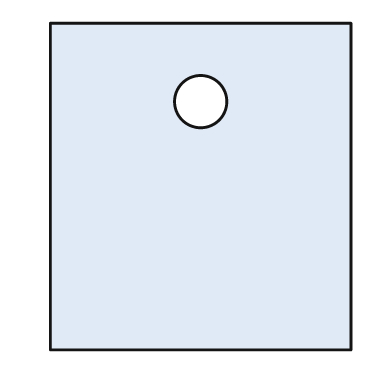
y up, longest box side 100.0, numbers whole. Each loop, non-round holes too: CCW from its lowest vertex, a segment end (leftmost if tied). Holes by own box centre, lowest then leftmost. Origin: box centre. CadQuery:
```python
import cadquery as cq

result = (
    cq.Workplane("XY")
    .moveTo(-46.0, -50.0)
    .lineTo(46.0, -50.0)
    .lineTo(46.0, 50.0)
    .lineTo(-46.0, 50.0)
    .close()
    .moveTo(0.0, 26.0)
    .circle(8.0)
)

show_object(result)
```